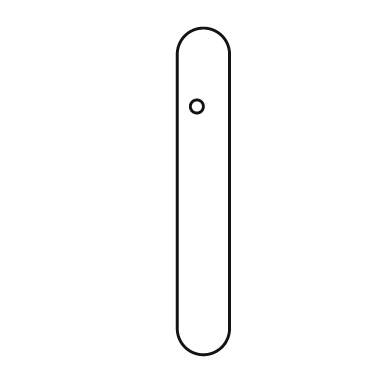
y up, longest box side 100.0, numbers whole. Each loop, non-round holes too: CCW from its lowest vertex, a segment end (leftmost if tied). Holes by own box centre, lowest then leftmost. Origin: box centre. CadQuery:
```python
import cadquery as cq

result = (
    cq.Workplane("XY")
    .moveTo(-8.0, -42.0)
    .threePointArc((0.0, -50.0), (8.0, -42.0))
    .lineTo(8.0, 42.0)
    .threePointArc((0.0, 50.0), (-8.0, 42.0))
    .close()
    .moveTo(-2.0, 26.0)
    .circle(2.0)
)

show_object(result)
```